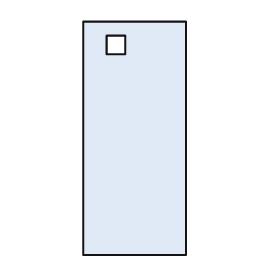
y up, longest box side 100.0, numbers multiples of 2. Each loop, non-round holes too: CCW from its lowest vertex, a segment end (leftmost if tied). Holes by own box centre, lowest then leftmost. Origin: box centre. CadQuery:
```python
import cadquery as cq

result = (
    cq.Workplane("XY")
    .moveTo(-22.0, -50.0)
    .lineTo(22.0, -50.0)
    .lineTo(22.0, 50.0)
    .lineTo(-22.0, 50.0)
    .close()
    .moveTo(-12.0, 36.0)
    .lineTo(-4.0, 36.0)
    .lineTo(-4.0, 44.0)
    .lineTo(-12.0, 44.0)
    .close()
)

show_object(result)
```